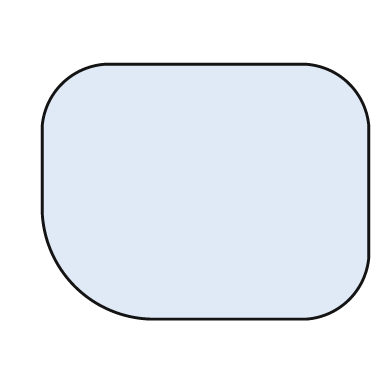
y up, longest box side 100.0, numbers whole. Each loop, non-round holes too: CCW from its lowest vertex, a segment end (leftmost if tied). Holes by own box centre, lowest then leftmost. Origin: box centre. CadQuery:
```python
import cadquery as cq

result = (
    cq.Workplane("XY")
    .moveTo(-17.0, -39.0)
    .lineTo(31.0, -39.0)
    .threePointArc((44.0, -33.0), (50.0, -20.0))
    .lineTo(50.0, 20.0)
    .threePointArc((44.0, 33.0), (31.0, 39.0))
    .lineTo(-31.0, 39.0)
    .threePointArc((-44.0, 33.0), (-50.0, 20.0))
    .lineTo(-50.0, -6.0)
    .threePointArc((-40.0, -29.0), (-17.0, -39.0))
    .close()
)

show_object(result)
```